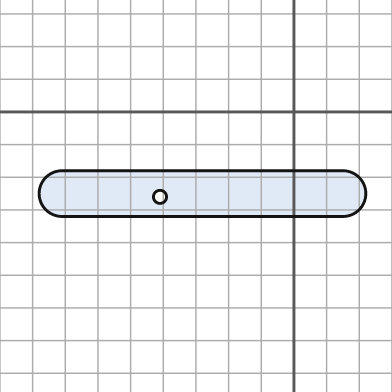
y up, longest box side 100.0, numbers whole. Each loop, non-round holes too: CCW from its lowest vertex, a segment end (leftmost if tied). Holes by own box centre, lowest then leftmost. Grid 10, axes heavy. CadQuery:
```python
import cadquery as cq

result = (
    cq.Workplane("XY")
    .moveTo(-71.0, -32.0)
    .lineTo(15.0, -32.0)
    .threePointArc((22.0, -25.0), (15.0, -18.0))
    .lineTo(-71.0, -18.0)
    .threePointArc((-78.0, -25.0), (-71.0, -32.0))
    .close()
    .moveTo(-41.0, -26.0)
    .circle(2.0)
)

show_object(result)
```